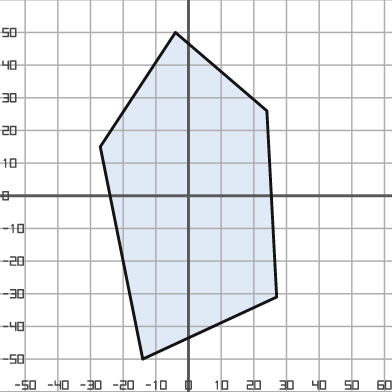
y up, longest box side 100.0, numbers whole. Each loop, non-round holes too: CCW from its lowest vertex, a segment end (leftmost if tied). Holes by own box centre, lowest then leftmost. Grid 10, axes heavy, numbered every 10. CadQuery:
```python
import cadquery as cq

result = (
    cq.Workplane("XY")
    .moveTo(-14.0, -50.0)
    .lineTo(27.0, -31.0)
    .lineTo(24.0, 26.0)
    .lineTo(-4.0, 50.0)
    .lineTo(-27.0, 15.0)
    .close()
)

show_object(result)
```